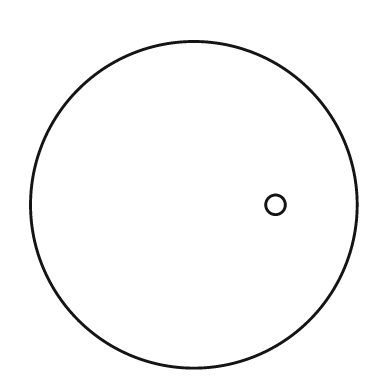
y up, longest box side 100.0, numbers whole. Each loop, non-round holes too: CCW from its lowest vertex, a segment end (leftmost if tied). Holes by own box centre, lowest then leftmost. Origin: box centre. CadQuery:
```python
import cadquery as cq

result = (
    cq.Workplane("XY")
    .moveTo(0.0, 0.0)
    .circle(50.0)
    .moveTo(25.0, 0.0)
    .circle(3.0)
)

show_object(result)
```